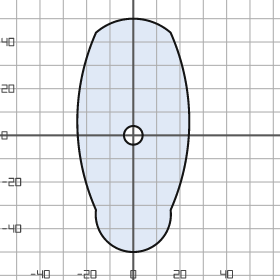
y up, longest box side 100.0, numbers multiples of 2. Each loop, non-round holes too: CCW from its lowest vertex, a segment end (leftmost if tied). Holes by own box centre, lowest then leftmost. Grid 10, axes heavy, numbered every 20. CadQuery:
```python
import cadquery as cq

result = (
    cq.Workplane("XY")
    .moveTo(-16.0, -32.0)
    .threePointArc((0.0, -50.0), (16.0, -32.0))
    .threePointArc((24.0, 6.0), (16.0, 44.0))
    .threePointArc((0.0, 50.0), (-16.0, 44.0))
    .threePointArc((-24.0, 6.0), (-16.0, -32.0))
    .close()
    .moveTo(0.0, 0.0)
    .circle(4.0)
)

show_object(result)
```